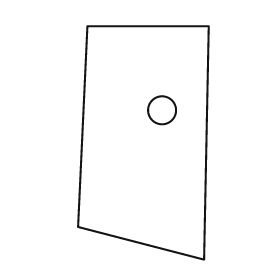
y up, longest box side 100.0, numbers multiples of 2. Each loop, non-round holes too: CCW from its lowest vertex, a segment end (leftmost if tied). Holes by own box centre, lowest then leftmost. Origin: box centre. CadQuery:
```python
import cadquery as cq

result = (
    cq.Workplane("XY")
    .moveTo(26.0, -50.0)
    .lineTo(28.0, 50.0)
    .lineTo(-24.0, 50.0)
    .lineTo(-28.0, -36.0)
    .close()
    .moveTo(8.0, 14.0)
    .circle(6.0)
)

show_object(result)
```